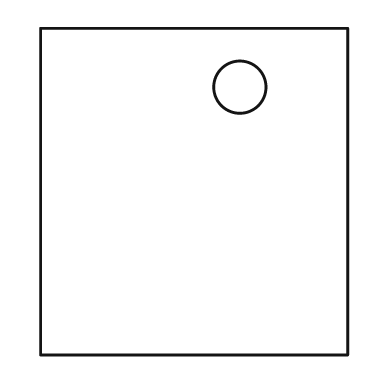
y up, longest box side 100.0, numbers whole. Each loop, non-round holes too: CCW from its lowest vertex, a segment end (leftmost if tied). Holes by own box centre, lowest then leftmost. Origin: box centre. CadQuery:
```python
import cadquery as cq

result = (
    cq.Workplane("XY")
    .moveTo(-47.0, -50.0)
    .lineTo(47.0, -50.0)
    .lineTo(47.0, 50.0)
    .lineTo(-47.0, 50.0)
    .close()
    .moveTo(14.0, 32.0)
    .circle(8.0)
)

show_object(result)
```